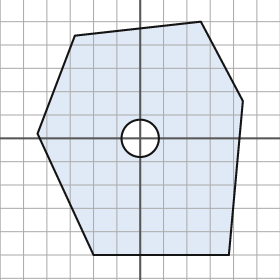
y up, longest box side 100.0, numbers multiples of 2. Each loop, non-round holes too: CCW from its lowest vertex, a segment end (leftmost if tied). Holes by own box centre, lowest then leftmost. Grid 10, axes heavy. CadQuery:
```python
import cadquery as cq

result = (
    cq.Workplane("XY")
    .moveTo(-20.0, -50.0)
    .lineTo(38.0, -50.0)
    .lineTo(44.0, 16.0)
    .lineTo(26.0, 50.0)
    .lineTo(-28.0, 44.0)
    .lineTo(-44.0, 2.0)
    .close()
    .moveTo(0.0, 0.0)
    .circle(8.0)
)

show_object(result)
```